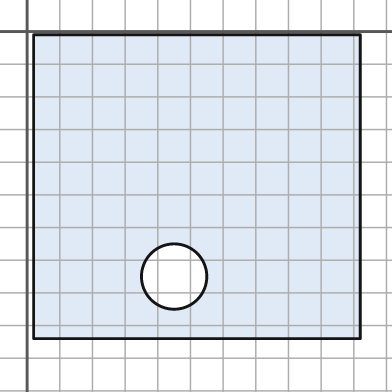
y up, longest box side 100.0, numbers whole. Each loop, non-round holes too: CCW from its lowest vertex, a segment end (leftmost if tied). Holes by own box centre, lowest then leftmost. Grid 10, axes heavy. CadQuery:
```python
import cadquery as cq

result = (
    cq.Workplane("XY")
    .moveTo(2.0, -94.0)
    .lineTo(102.0, -94.0)
    .lineTo(102.0, -1.0)
    .lineTo(2.0, -1.0)
    .close()
    .moveTo(45.0, -75.0)
    .circle(10.0)
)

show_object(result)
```